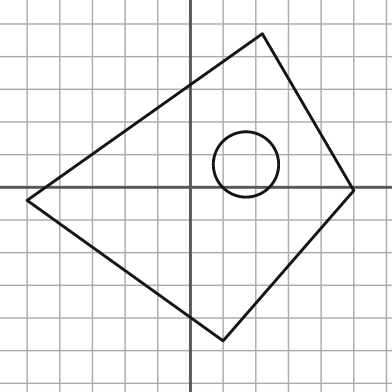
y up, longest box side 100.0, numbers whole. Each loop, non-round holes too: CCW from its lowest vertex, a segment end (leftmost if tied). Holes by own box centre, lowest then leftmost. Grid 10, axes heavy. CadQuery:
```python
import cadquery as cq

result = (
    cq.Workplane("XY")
    .moveTo(10.0, -47.0)
    .lineTo(50.0, -1.0)
    .lineTo(22.0, 47.0)
    .lineTo(-50.0, -4.0)
    .close()
    .moveTo(17.0, 7.0)
    .circle(10.0)
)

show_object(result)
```